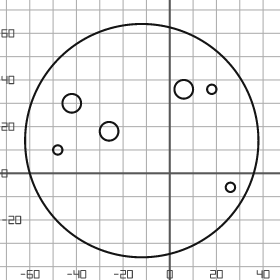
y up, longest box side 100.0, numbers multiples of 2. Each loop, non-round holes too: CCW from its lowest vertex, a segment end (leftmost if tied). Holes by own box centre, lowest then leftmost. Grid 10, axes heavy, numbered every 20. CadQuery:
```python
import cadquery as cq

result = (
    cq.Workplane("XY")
    .moveTo(-12.0, 14.0)
    .circle(50.0)
    .moveTo(26.0, -6.0)
    .circle(2.0)
    .moveTo(-48.0, 10.0)
    .circle(2.0)
    .moveTo(-26.0, 18.0)
    .circle(4.0)
    .moveTo(-42.0, 30.0)
    .circle(4.0)
    .moveTo(6.0, 36.0)
    .circle(4.0)
    .moveTo(18.0, 36.0)
    .circle(2.0)
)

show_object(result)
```